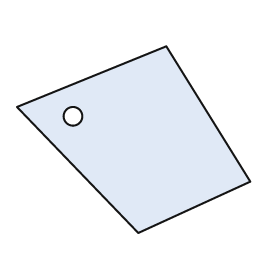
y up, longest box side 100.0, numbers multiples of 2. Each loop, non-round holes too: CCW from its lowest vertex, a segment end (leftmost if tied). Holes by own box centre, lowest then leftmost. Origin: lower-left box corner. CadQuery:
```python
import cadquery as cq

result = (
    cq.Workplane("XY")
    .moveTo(52.0, 0.0)
    .lineTo(100.0, 22.0)
    .lineTo(64.0, 80.0)
    .lineTo(0.0, 54.0)
    .close()
    .moveTo(24.0, 50.0)
    .circle(4.0)
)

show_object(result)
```